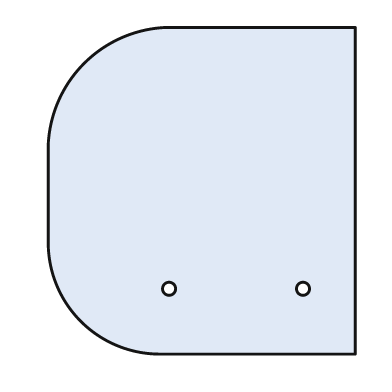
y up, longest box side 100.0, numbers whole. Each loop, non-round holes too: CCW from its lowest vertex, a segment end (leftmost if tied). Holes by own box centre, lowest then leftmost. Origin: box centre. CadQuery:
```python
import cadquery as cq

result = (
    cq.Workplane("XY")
    .moveTo(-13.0, -50.0)
    .lineTo(47.0, -50.0)
    .lineTo(47.0, 50.0)
    .lineTo(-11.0, 50.0)
    .threePointArc((-36.0, 39.0), (-47.0, 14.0))
    .lineTo(-47.0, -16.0)
    .threePointArc((-37.0, -40.0), (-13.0, -50.0))
    .close()
    .moveTo(-10.0, -30.0)
    .circle(2.0)
    .moveTo(31.0, -30.0)
    .circle(2.0)
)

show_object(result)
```